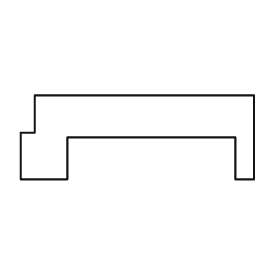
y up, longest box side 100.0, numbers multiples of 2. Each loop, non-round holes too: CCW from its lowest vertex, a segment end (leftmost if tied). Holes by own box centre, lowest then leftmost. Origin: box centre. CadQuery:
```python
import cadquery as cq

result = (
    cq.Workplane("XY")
    .moveTo(-50.0, -18.0)
    .lineTo(-30.0, -18.0)
    .lineTo(-30.0, 0.0)
    .lineTo(42.0, 0.0)
    .lineTo(42.0, -18.0)
    .lineTo(50.0, -18.0)
    .lineTo(50.0, 18.0)
    .lineTo(-44.0, 18.0)
    .lineTo(-44.0, 2.0)
    .lineTo(-50.0, 2.0)
    .close()
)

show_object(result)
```